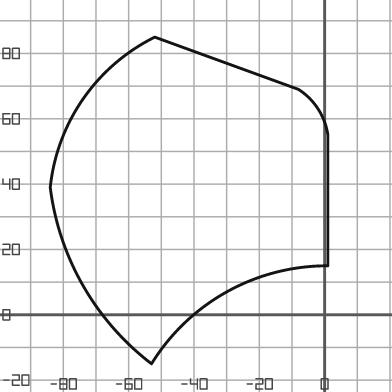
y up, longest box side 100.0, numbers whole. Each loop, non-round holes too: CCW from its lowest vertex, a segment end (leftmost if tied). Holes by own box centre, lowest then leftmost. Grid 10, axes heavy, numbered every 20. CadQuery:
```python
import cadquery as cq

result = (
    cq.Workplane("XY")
    .moveTo(-53.0, -15.0)
    .threePointArc((-30.0, 7.0), (1.0, 15.0))
    .lineTo(1.0, 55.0)
    .threePointArc((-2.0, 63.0), (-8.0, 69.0))
    .lineTo(-52.0, 85.0)
    .threePointArc((-74.0, 66.0), (-84.0, 39.0))
    .threePointArc((-74.0, 9.0), (-53.0, -15.0))
    .close()
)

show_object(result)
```